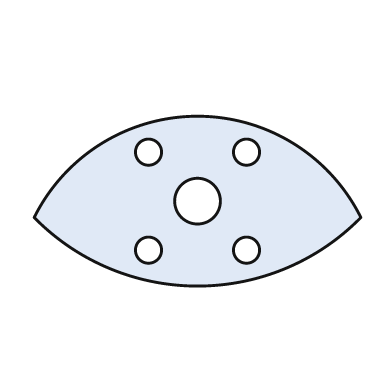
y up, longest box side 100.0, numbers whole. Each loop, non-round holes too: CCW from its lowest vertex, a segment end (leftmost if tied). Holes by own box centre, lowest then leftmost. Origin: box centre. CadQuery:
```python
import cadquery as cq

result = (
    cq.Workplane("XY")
    .moveTo(-50.0, -5.0)
    .threePointArc((0.0, -26.0), (50.0, -5.0))
    .threePointArc((0.0, 26.0), (-50.0, -5.0))
    .close()
    .moveTo(-15.0, -15.0)
    .circle(4.0)
    .moveTo(15.0, -15.0)
    .circle(4.0)
    .moveTo(0.0, 0.0)
    .circle(7.0)
    .moveTo(-15.0, 15.0)
    .circle(4.0)
    .moveTo(15.0, 15.0)
    .circle(4.0)
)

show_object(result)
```